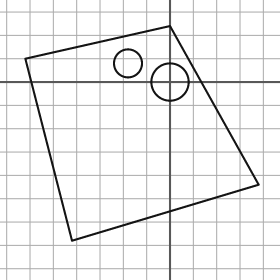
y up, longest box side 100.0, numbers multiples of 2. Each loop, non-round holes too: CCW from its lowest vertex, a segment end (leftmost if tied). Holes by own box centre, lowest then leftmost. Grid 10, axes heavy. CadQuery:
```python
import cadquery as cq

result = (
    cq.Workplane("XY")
    .moveTo(-42.0, -68.0)
    .lineTo(38.0, -44.0)
    .lineTo(0.0, 24.0)
    .lineTo(-62.0, 10.0)
    .close()
    .moveTo(0.0, 0.0)
    .circle(8.0)
    .moveTo(-18.0, 8.0)
    .circle(6.0)
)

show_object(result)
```